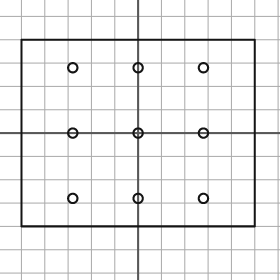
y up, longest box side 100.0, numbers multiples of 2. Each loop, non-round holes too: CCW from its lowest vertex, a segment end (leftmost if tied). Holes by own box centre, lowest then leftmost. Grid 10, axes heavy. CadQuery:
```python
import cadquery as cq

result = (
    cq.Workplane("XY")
    .moveTo(-50.0, -40.0)
    .lineTo(50.0, -40.0)
    .lineTo(50.0, 40.0)
    .lineTo(-50.0, 40.0)
    .close()
    .moveTo(-28.0, -28.0)
    .circle(2.0)
    .moveTo(0.0, -28.0)
    .circle(2.0)
    .moveTo(28.0, -28.0)
    .circle(2.0)
    .moveTo(-28.0, 0.0)
    .circle(2.0)
    .moveTo(0.0, 0.0)
    .circle(2.0)
    .moveTo(28.0, 0.0)
    .circle(2.0)
    .moveTo(-28.0, 28.0)
    .circle(2.0)
    .moveTo(0.0, 28.0)
    .circle(2.0)
    .moveTo(28.0, 28.0)
    .circle(2.0)
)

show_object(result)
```